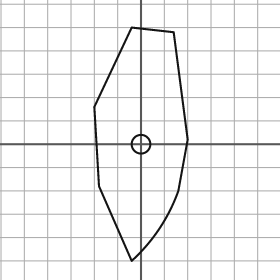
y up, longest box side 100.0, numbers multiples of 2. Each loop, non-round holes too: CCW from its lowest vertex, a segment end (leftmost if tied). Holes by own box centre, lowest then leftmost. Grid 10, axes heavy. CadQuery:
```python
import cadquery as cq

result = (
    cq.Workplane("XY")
    .moveTo(-4.0, -50.0)
    .threePointArc((8.0, -36.0), (16.0, -20.0))
    .lineTo(20.0, 2.0)
    .lineTo(14.0, 48.0)
    .lineTo(-4.0, 50.0)
    .lineTo(-20.0, 16.0)
    .lineTo(-18.0, -18.0)
    .close()
    .moveTo(0.0, 0.0)
    .circle(4.0)
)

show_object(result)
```